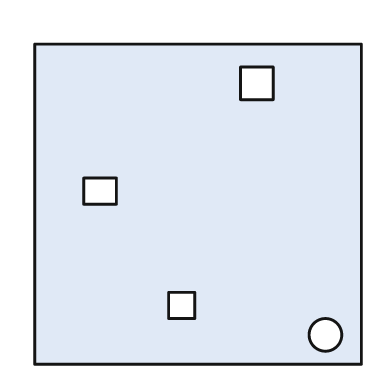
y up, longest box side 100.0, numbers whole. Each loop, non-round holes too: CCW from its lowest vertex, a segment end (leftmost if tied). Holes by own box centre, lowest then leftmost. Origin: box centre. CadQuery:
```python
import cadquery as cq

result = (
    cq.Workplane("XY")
    .moveTo(-50.0, -49.0)
    .lineTo(50.0, -49.0)
    .lineTo(50.0, 49.0)
    .lineTo(-50.0, 49.0)
    .close()
    .moveTo(39.0, -40.0)
    .circle(5.0)
    .moveTo(-9.0, -35.0)
    .lineTo(-1.0, -35.0)
    .lineTo(-1.0, -27.0)
    .lineTo(-9.0, -27.0)
    .close()
    .moveTo(-35.0, 0.0)
    .lineTo(-25.0, 0.0)
    .lineTo(-25.0, 8.0)
    .lineTo(-35.0, 8.0)
    .close()
    .moveTo(13.0, 32.0)
    .lineTo(23.0, 32.0)
    .lineTo(23.0, 42.0)
    .lineTo(13.0, 42.0)
    .close()
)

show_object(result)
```